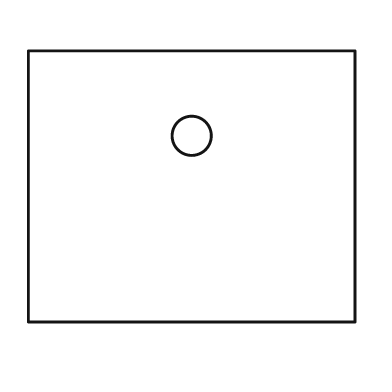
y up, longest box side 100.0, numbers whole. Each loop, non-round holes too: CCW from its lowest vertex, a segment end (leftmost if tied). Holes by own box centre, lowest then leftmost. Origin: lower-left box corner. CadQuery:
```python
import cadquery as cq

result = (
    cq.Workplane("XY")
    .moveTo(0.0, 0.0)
    .lineTo(100.0, 0.0)
    .lineTo(100.0, 83.0)
    .lineTo(0.0, 83.0)
    .close()
    .moveTo(50.0, 57.0)
    .circle(6.0)
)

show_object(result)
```